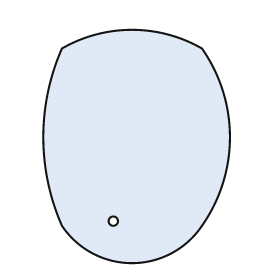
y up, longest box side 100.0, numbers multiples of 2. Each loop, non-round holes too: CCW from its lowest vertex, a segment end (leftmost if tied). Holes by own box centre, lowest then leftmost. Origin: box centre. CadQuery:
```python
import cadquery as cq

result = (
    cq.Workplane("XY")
    .moveTo(-32.0, -34.0)
    .threePointArc((-2.0, -50.0), (28.0, -34.0))
    .threePointArc((40.0, 4.0), (28.0, 42.0))
    .threePointArc((-2.0, 50.0), (-32.0, 42.0))
    .threePointArc((-40.0, 4.0), (-32.0, -34.0))
    .close()
    .moveTo(-10.0, -32.0)
    .circle(2.0)
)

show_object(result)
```